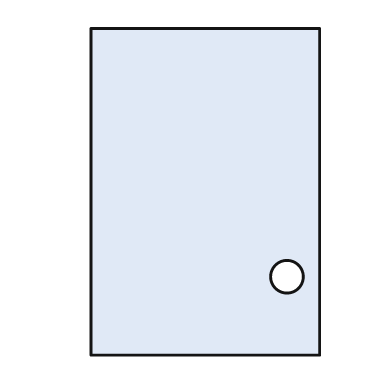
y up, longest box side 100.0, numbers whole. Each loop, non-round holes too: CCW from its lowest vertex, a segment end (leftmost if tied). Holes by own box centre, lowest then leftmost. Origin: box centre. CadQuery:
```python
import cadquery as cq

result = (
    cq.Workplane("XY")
    .moveTo(-35.0, -50.0)
    .lineTo(35.0, -50.0)
    .lineTo(35.0, 50.0)
    .lineTo(-35.0, 50.0)
    .close()
    .moveTo(25.0, -26.0)
    .circle(5.0)
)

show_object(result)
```